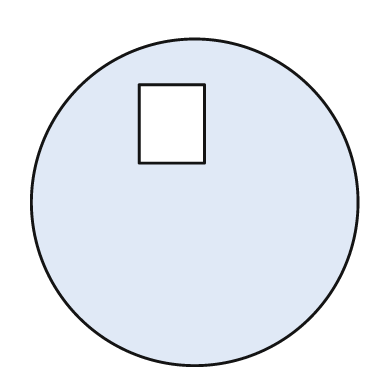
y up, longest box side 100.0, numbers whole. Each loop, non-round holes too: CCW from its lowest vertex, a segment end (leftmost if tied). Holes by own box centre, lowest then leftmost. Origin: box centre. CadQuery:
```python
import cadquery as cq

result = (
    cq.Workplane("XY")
    .moveTo(0.0, 0.0)
    .circle(50.0)
    .moveTo(-17.0, 12.0)
    .lineTo(3.0, 12.0)
    .lineTo(3.0, 36.0)
    .lineTo(-17.0, 36.0)
    .close()
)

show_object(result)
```